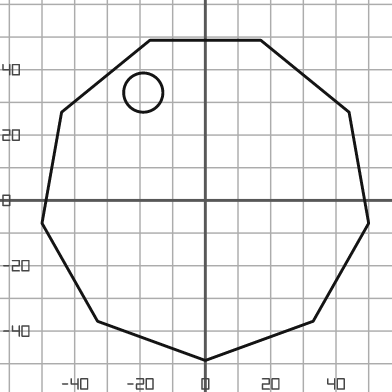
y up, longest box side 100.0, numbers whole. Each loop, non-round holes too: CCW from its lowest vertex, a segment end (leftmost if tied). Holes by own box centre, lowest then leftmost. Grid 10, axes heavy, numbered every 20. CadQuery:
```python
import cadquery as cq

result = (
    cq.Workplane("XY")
    .moveTo(0.0, -49.0)
    .lineTo(33.0, -37.0)
    .lineTo(50.0, -7.0)
    .lineTo(44.0, 27.0)
    .lineTo(17.0, 49.0)
    .lineTo(-17.0, 49.0)
    .lineTo(-44.0, 27.0)
    .lineTo(-50.0, -7.0)
    .lineTo(-33.0, -37.0)
    .close()
    .moveTo(-19.0, 33.0)
    .circle(6.0)
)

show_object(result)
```